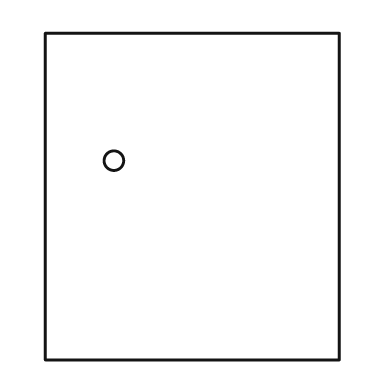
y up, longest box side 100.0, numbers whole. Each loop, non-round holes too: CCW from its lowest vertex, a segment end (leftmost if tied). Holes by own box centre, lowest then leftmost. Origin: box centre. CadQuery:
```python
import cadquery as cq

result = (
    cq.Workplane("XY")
    .moveTo(-45.0, -50.0)
    .lineTo(45.0, -50.0)
    .lineTo(45.0, 50.0)
    .lineTo(-45.0, 50.0)
    .close()
    .moveTo(-24.0, 11.0)
    .circle(3.0)
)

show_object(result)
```